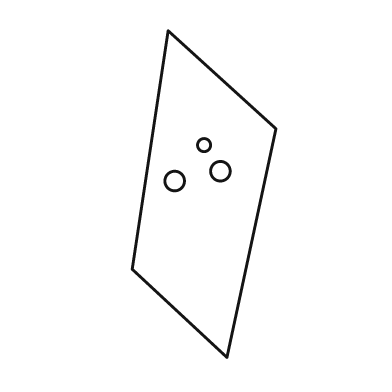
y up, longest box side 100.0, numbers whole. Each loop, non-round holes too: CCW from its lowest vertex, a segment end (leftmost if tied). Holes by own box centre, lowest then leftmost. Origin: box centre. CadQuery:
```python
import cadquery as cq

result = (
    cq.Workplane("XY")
    .moveTo(7.0, -50.0)
    .lineTo(22.0, 20.0)
    .lineTo(-11.0, 50.0)
    .lineTo(-22.0, -23.0)
    .close()
    .moveTo(-9.0, 4.0)
    .circle(3.0)
    .moveTo(5.0, 7.0)
    .circle(3.0)
    .moveTo(0.0, 15.0)
    .circle(2.0)
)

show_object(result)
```